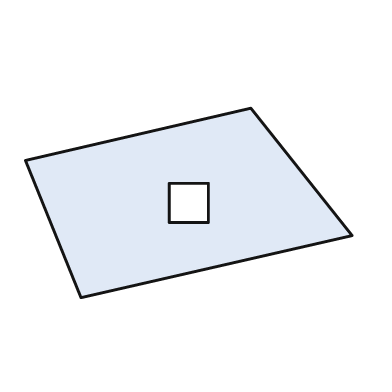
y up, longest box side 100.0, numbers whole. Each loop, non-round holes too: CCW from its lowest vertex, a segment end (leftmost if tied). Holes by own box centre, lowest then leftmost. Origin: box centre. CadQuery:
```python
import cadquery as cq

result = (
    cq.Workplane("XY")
    .moveTo(-33.0, -29.0)
    .lineTo(50.0, -10.0)
    .lineTo(19.0, 29.0)
    .lineTo(-50.0, 13.0)
    .close()
    .moveTo(-6.0, -6.0)
    .lineTo(6.0, -6.0)
    .lineTo(6.0, 6.0)
    .lineTo(-6.0, 6.0)
    .close()
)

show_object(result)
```